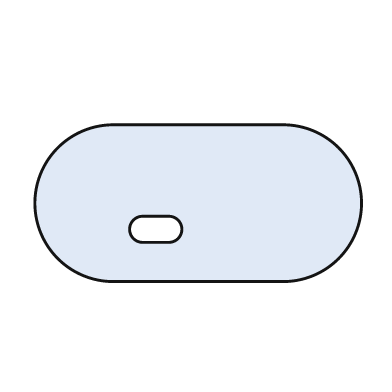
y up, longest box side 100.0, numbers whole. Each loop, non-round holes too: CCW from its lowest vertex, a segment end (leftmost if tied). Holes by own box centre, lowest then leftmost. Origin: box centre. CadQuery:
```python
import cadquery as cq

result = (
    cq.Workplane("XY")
    .moveTo(-26.0, -24.0)
    .lineTo(26.0, -24.0)
    .threePointArc((50.0, 0.0), (26.0, 24.0))
    .lineTo(-26.0, 24.0)
    .threePointArc((-50.0, 0.0), (-26.0, -24.0))
    .close()
    .moveTo(-17.0, -12.0)
    .lineTo(-9.0, -12.0)
    .threePointArc((-5.0, -8.0), (-9.0, -4.0))
    .lineTo(-17.0, -4.0)
    .threePointArc((-21.0, -8.0), (-17.0, -12.0))
    .close()
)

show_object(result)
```